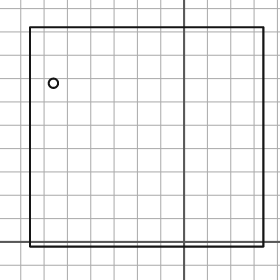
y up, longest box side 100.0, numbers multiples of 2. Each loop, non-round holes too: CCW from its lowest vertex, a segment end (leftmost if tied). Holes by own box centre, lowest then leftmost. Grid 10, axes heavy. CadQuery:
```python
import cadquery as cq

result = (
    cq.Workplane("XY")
    .moveTo(-66.0, -2.0)
    .lineTo(34.0, -2.0)
    .lineTo(34.0, 92.0)
    .lineTo(-66.0, 92.0)
    .close()
    .moveTo(-56.0, 68.0)
    .circle(2.0)
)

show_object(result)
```